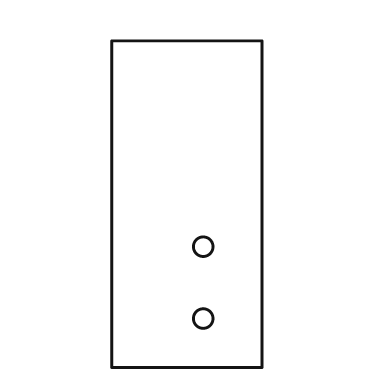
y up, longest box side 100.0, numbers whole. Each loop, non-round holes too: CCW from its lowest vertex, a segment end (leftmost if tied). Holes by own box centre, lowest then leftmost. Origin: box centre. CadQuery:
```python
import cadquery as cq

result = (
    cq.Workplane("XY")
    .moveTo(-23.0, -50.0)
    .lineTo(23.0, -50.0)
    .lineTo(23.0, 50.0)
    .lineTo(-23.0, 50.0)
    .close()
    .moveTo(5.0, -35.0)
    .circle(3.0)
    .moveTo(5.0, -13.0)
    .circle(3.0)
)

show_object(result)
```